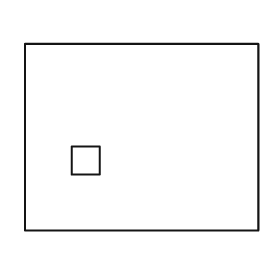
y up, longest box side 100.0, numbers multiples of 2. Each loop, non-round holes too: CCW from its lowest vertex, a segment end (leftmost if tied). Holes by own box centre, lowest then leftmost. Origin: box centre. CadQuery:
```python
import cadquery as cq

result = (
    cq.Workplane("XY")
    .moveTo(-50.0, -40.0)
    .lineTo(50.0, -40.0)
    .lineTo(50.0, 40.0)
    .lineTo(-50.0, 40.0)
    .close()
    .moveTo(-30.0, -16.0)
    .lineTo(-18.0, -16.0)
    .lineTo(-18.0, -4.0)
    .lineTo(-30.0, -4.0)
    .close()
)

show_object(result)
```